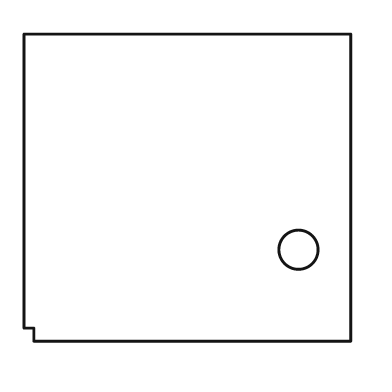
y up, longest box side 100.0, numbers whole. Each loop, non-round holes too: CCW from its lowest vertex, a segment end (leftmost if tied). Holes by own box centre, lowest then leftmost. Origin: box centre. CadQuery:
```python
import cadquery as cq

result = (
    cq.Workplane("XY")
    .moveTo(-47.0, -47.0)
    .lineTo(50.0, -47.0)
    .lineTo(50.0, 47.0)
    .lineTo(-50.0, 47.0)
    .lineTo(-50.0, -43.0)
    .lineTo(-47.0, -43.0)
    .close()
    .moveTo(34.0, -19.0)
    .circle(6.0)
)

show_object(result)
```